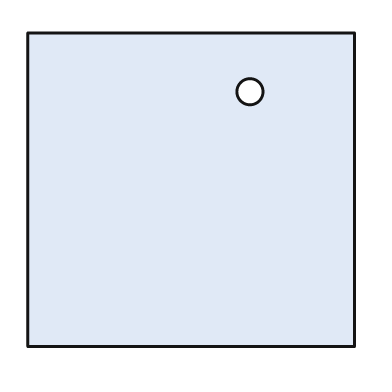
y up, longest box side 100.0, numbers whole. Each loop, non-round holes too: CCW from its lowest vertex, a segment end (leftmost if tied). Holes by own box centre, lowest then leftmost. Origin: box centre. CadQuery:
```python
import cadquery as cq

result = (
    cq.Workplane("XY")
    .moveTo(-50.0, -48.0)
    .lineTo(50.0, -48.0)
    .lineTo(50.0, 48.0)
    .lineTo(-50.0, 48.0)
    .close()
    .moveTo(18.0, 30.0)
    .circle(4.0)
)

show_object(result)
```